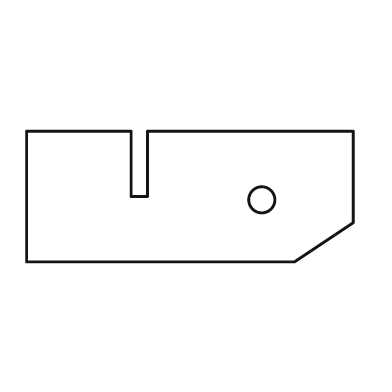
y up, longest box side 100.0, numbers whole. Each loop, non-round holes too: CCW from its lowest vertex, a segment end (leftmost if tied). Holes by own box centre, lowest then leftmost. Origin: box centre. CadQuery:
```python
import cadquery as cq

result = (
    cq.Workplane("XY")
    .moveTo(-50.0, -20.0)
    .lineTo(32.0, -20.0)
    .lineTo(50.0, -8.0)
    .lineTo(50.0, 20.0)
    .lineTo(-13.0, 20.0)
    .lineTo(-13.0, 0.0)
    .lineTo(-18.0, 0.0)
    .lineTo(-18.0, 20.0)
    .lineTo(-50.0, 20.0)
    .close()
    .moveTo(22.0, -1.0)
    .circle(4.0)
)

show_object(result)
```